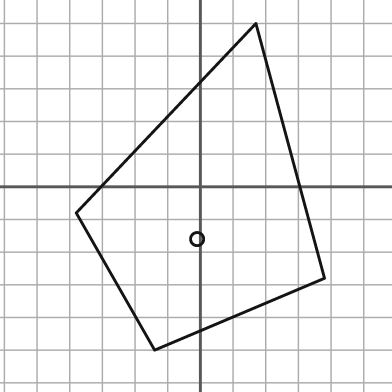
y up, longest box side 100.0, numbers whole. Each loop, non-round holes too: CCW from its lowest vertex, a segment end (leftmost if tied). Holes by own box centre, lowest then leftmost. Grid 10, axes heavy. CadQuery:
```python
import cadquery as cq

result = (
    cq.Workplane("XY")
    .moveTo(-14.0, -50.0)
    .lineTo(38.0, -28.0)
    .lineTo(17.0, 50.0)
    .lineTo(-38.0, -8.0)
    .close()
    .moveTo(-1.0, -16.0)
    .circle(2.0)
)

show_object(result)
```